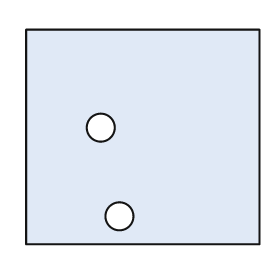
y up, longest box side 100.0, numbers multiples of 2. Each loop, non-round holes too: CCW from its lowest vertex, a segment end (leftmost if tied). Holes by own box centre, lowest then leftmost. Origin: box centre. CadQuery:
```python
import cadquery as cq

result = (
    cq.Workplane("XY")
    .moveTo(-50.0, -46.0)
    .lineTo(50.0, -46.0)
    .lineTo(50.0, 46.0)
    .lineTo(-50.0, 46.0)
    .close()
    .moveTo(-10.0, -34.0)
    .circle(6.0)
    .moveTo(-18.0, 4.0)
    .circle(6.0)
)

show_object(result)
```